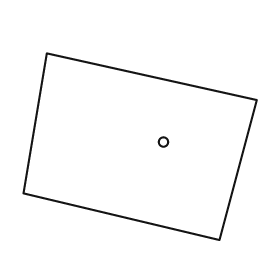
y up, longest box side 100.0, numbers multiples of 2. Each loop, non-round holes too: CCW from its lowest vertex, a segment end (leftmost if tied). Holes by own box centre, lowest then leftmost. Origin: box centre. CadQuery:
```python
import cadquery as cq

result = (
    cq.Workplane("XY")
    .moveTo(34.0, -40.0)
    .lineTo(50.0, 20.0)
    .lineTo(-40.0, 40.0)
    .lineTo(-50.0, -20.0)
    .close()
    .moveTo(10.0, 2.0)
    .circle(2.0)
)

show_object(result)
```